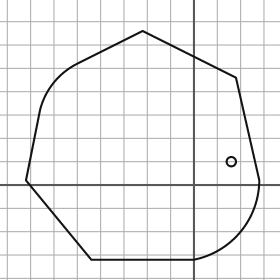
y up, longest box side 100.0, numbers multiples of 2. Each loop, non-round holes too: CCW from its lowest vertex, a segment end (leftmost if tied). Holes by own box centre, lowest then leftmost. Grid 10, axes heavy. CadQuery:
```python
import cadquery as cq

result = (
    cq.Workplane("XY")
    .moveTo(-44.0, -32.0)
    .lineTo(0.0, -32.0)
    .threePointArc((20.0, -20.0), (28.0, 2.0))
    .lineTo(18.0, 46.0)
    .lineTo(-22.0, 66.0)
    .lineTo(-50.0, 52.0)
    .threePointArc((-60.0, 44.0), (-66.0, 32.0))
    .lineTo(-72.0, 2.0)
    .close()
    .moveTo(16.0, 10.0)
    .circle(2.0)
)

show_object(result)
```